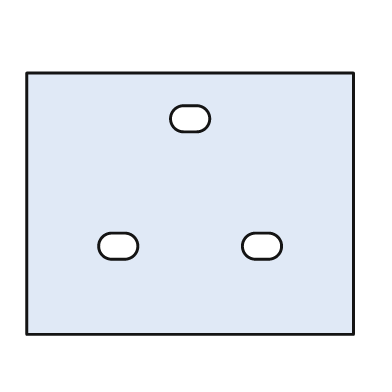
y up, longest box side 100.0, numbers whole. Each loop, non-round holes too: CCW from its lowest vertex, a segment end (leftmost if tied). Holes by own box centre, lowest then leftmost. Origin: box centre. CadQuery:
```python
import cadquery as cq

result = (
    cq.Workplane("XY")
    .moveTo(-50.0, -40.0)
    .lineTo(50.0, -40.0)
    .lineTo(50.0, 40.0)
    .lineTo(-50.0, 40.0)
    .close()
    .moveTo(-24.0, -17.0)
    .lineTo(-20.0, -17.0)
    .threePointArc((-16.0, -13.0), (-20.0, -9.0))
    .lineTo(-24.0, -9.0)
    .threePointArc((-28.0, -13.0), (-24.0, -17.0))
    .close()
    .moveTo(20.0, -17.0)
    .lineTo(24.0, -17.0)
    .threePointArc((28.0, -13.0), (24.0, -9.0))
    .lineTo(20.0, -9.0)
    .threePointArc((16.0, -13.0), (20.0, -17.0))
    .close()
    .moveTo(-2.0, 22.0)
    .lineTo(2.0, 22.0)
    .threePointArc((6.0, 26.0), (2.0, 30.0))
    .lineTo(-2.0, 30.0)
    .threePointArc((-6.0, 26.0), (-2.0, 22.0))
    .close()
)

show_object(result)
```